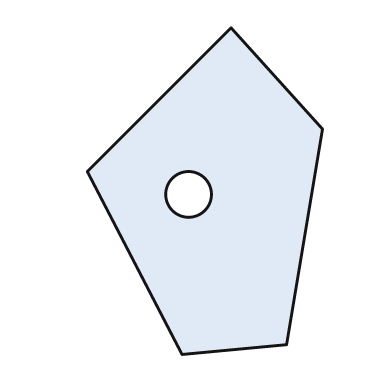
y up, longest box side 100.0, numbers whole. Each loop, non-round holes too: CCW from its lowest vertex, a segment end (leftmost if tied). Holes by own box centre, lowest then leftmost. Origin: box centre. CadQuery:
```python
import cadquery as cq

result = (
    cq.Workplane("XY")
    .moveTo(-7.0, -50.0)
    .lineTo(25.0, -47.0)
    .lineTo(36.0, 19.0)
    .lineTo(8.0, 50.0)
    .lineTo(-36.0, 6.0)
    .close()
    .moveTo(-5.0, -1.0)
    .circle(7.0)
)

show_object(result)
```